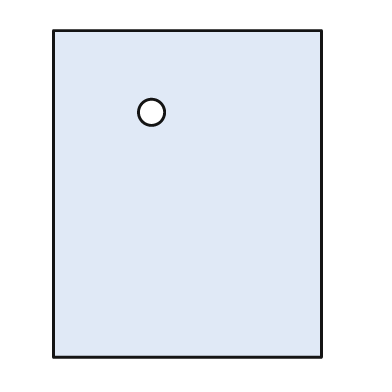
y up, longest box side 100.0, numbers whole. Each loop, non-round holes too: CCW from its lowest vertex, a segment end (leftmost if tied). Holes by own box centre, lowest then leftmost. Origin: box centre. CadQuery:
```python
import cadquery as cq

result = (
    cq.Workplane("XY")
    .moveTo(-41.0, -50.0)
    .lineTo(41.0, -50.0)
    .lineTo(41.0, 50.0)
    .lineTo(-41.0, 50.0)
    .close()
    .moveTo(-11.0, 25.0)
    .circle(4.0)
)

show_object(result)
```